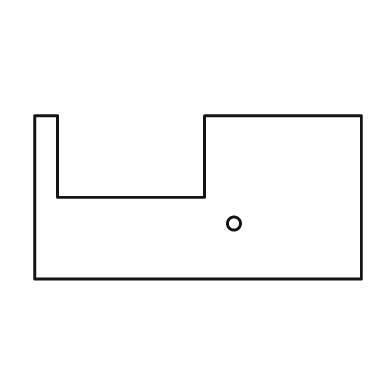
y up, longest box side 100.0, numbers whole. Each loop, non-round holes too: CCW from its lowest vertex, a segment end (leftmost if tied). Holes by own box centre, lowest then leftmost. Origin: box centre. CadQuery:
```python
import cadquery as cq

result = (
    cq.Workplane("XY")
    .moveTo(-50.0, -25.0)
    .lineTo(50.0, -25.0)
    .lineTo(50.0, 25.0)
    .lineTo(2.0, 25.0)
    .lineTo(2.0, 0.0)
    .lineTo(-43.0, 0.0)
    .lineTo(-43.0, 25.0)
    .lineTo(-50.0, 25.0)
    .close()
    .moveTo(11.0, -8.0)
    .circle(2.0)
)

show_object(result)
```